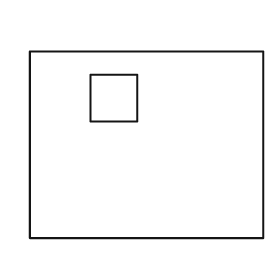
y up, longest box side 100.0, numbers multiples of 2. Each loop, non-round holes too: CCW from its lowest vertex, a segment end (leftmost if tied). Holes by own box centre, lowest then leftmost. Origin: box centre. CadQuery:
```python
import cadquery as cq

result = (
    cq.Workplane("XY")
    .moveTo(-50.0, -40.0)
    .lineTo(50.0, -40.0)
    .lineTo(50.0, 40.0)
    .lineTo(-50.0, 40.0)
    .close()
    .moveTo(-24.0, 10.0)
    .lineTo(-4.0, 10.0)
    .lineTo(-4.0, 30.0)
    .lineTo(-24.0, 30.0)
    .close()
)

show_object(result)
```